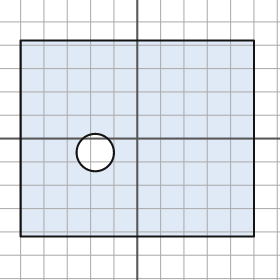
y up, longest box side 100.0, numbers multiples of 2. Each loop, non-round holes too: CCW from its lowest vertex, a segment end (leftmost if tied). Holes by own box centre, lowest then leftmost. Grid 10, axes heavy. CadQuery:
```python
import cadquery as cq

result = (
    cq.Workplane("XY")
    .moveTo(-50.0, -42.0)
    .lineTo(50.0, -42.0)
    .lineTo(50.0, 42.0)
    .lineTo(-50.0, 42.0)
    .close()
    .moveTo(-18.0, -6.0)
    .circle(8.0)
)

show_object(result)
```